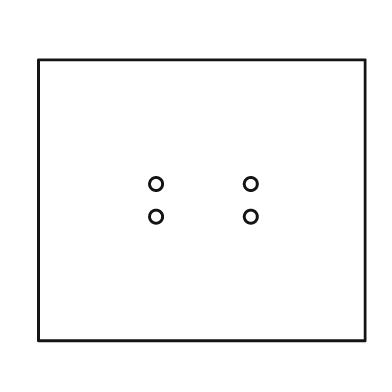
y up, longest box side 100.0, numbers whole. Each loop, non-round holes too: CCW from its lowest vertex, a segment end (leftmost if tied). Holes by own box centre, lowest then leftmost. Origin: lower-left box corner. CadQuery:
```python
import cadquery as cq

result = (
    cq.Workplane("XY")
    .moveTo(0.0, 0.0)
    .lineTo(100.0, 0.0)
    .lineTo(100.0, 86.0)
    .lineTo(0.0, 86.0)
    .close()
    .moveTo(36.0, 38.0)
    .circle(2.0)
    .moveTo(65.0, 38.0)
    .circle(2.0)
    .moveTo(36.0, 48.0)
    .circle(2.0)
    .moveTo(65.0, 48.0)
    .circle(2.0)
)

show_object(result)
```